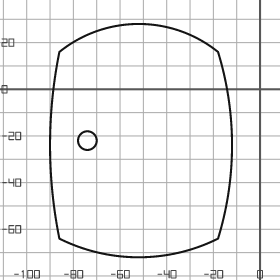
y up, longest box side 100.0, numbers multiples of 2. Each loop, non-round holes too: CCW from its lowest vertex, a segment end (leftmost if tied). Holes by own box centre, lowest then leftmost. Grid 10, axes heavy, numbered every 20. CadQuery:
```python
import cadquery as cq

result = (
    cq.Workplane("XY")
    .moveTo(-86.0, -64.0)
    .threePointArc((-52.0, -72.0), (-18.0, -64.0))
    .threePointArc((-12.0, -24.0), (-18.0, 16.0))
    .threePointArc((-52.0, 28.0), (-86.0, 16.0))
    .threePointArc((-90.0, -24.0), (-86.0, -64.0))
    .close()
    .moveTo(-74.0, -22.0)
    .circle(4.0)
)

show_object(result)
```